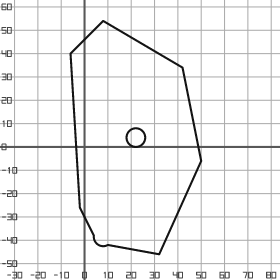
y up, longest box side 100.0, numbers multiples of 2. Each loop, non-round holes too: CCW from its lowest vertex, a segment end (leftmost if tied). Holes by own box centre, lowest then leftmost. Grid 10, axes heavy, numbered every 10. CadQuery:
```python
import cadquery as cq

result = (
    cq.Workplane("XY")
    .moveTo(32.0, -46.0)
    .lineTo(50.0, -6.0)
    .lineTo(42.0, 34.0)
    .lineTo(8.0, 54.0)
    .lineTo(-6.0, 40.0)
    .lineTo(-2.0, -26.0)
    .lineTo(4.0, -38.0)
    .threePointArc((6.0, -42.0), (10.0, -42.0))
    .close()
    .moveTo(22.0, 4.0)
    .circle(4.0)
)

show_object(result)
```